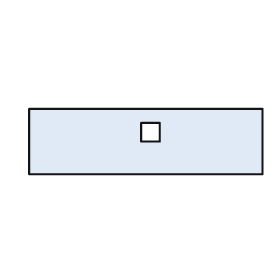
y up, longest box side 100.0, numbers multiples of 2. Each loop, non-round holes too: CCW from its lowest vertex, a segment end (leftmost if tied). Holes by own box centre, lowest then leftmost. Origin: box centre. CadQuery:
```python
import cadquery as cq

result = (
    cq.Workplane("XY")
    .moveTo(-50.0, -14.0)
    .lineTo(50.0, -14.0)
    .lineTo(50.0, 14.0)
    .lineTo(-50.0, 14.0)
    .close()
    .moveTo(-2.0, 0.0)
    .lineTo(6.0, 0.0)
    .lineTo(6.0, 8.0)
    .lineTo(-2.0, 8.0)
    .close()
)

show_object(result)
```